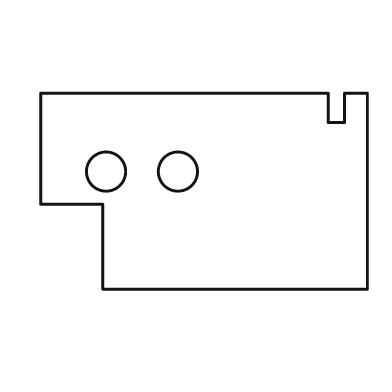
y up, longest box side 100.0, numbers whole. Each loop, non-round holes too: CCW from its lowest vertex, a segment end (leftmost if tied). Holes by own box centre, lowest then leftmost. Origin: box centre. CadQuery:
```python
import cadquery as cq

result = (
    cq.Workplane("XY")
    .moveTo(-31.0, -30.0)
    .lineTo(50.0, -30.0)
    .lineTo(50.0, 30.0)
    .lineTo(43.0, 30.0)
    .lineTo(43.0, 21.0)
    .lineTo(38.0, 21.0)
    .lineTo(38.0, 30.0)
    .lineTo(-50.0, 30.0)
    .lineTo(-50.0, -4.0)
    .lineTo(-31.0, -4.0)
    .close()
    .moveTo(-30.0, 6.0)
    .circle(6.0)
    .moveTo(-8.0, 6.0)
    .circle(6.0)
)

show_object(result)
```